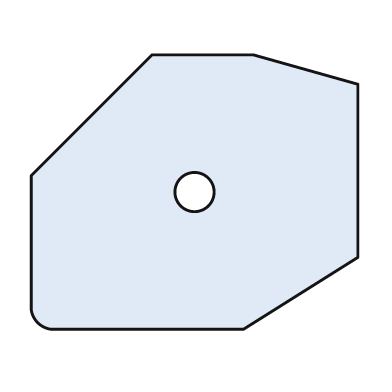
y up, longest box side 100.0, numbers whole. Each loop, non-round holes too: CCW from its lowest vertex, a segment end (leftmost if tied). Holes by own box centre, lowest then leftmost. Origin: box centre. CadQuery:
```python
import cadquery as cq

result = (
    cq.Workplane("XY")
    .moveTo(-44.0, -42.0)
    .lineTo(15.0, -42.0)
    .lineTo(50.0, -20.0)
    .lineTo(50.0, 33.0)
    .lineTo(18.0, 42.0)
    .lineTo(-13.0, 42.0)
    .lineTo(-50.0, 5.0)
    .lineTo(-50.0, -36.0)
    .threePointArc((-48.0, -40.0), (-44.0, -42.0))
    .close()
    .moveTo(0.0, 0.0)
    .circle(6.0)
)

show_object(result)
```